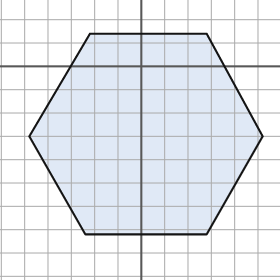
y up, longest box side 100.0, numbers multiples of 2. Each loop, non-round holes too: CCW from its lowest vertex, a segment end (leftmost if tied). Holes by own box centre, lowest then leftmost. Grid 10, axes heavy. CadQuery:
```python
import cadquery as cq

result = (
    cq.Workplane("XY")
    .moveTo(-24.0, -72.0)
    .lineTo(28.0, -72.0)
    .lineTo(52.0, -30.0)
    .lineTo(28.0, 14.0)
    .lineTo(-22.0, 14.0)
    .lineTo(-48.0, -30.0)
    .close()
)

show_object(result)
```